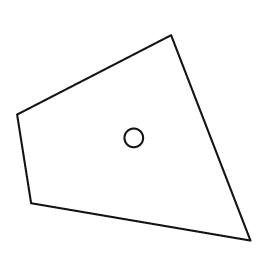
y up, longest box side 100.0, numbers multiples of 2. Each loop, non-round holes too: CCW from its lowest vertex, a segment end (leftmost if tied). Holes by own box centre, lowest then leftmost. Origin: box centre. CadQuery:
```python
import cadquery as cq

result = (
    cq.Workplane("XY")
    .moveTo(50.0, -44.0)
    .lineTo(16.0, 44.0)
    .lineTo(-50.0, 10.0)
    .lineTo(-44.0, -28.0)
    .close()
    .moveTo(0.0, 0.0)
    .circle(4.0)
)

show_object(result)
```